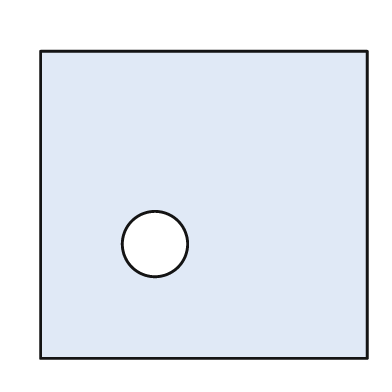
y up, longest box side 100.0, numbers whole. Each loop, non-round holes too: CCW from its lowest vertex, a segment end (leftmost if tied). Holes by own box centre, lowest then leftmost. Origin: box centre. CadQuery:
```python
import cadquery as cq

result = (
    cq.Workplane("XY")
    .moveTo(-50.0, -47.0)
    .lineTo(50.0, -47.0)
    .lineTo(50.0, 47.0)
    .lineTo(-50.0, 47.0)
    .close()
    .moveTo(-15.0, -12.0)
    .circle(10.0)
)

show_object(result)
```